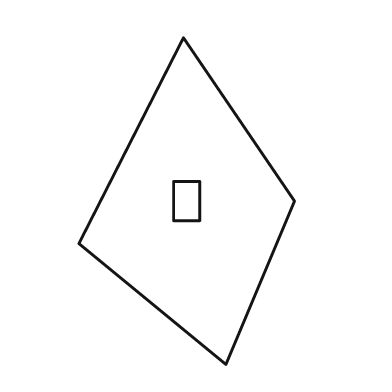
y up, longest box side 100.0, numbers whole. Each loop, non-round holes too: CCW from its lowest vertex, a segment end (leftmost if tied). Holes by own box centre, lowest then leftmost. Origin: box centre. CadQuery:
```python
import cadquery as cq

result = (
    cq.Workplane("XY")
    .moveTo(12.0, -50.0)
    .lineTo(33.0, 0.0)
    .lineTo(-1.0, 50.0)
    .lineTo(-33.0, -13.0)
    .close()
    .moveTo(-4.0, -6.0)
    .lineTo(4.0, -6.0)
    .lineTo(4.0, 6.0)
    .lineTo(-4.0, 6.0)
    .close()
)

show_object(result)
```